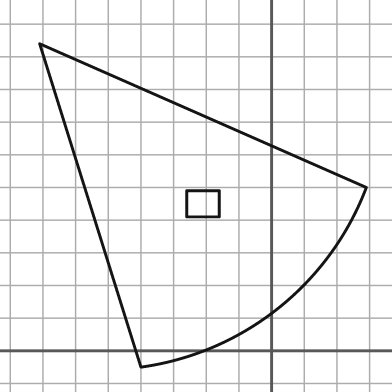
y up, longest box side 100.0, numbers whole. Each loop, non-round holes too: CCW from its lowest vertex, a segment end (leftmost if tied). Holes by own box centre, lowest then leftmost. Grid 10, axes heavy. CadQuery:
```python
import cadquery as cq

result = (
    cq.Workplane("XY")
    .moveTo(-40.0, -5.0)
    .threePointArc((2.0, 13.0), (29.0, 50.0))
    .lineTo(-71.0, 94.0)
    .close()
    .moveTo(-26.0, 41.0)
    .lineTo(-16.0, 41.0)
    .lineTo(-16.0, 49.0)
    .lineTo(-26.0, 49.0)
    .close()
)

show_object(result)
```